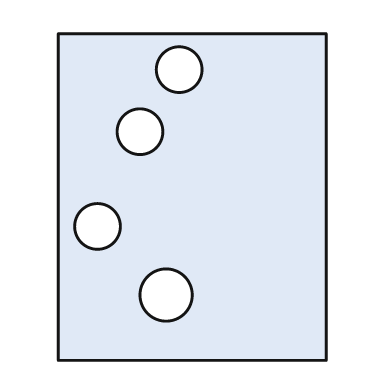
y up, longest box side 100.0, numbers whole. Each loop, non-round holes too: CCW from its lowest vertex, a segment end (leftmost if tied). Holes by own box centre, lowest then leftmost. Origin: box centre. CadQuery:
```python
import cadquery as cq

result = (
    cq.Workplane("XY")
    .moveTo(-41.0, -50.0)
    .lineTo(41.0, -50.0)
    .lineTo(41.0, 50.0)
    .lineTo(-41.0, 50.0)
    .close()
    .moveTo(-8.0, -30.0)
    .circle(8.0)
    .moveTo(-29.0, -9.0)
    .circle(7.0)
    .moveTo(-16.0, 20.0)
    .circle(7.0)
    .moveTo(-4.0, 39.0)
    .circle(7.0)
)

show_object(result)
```